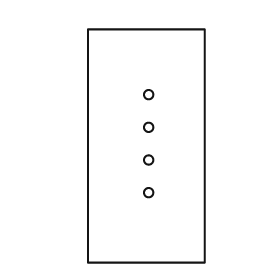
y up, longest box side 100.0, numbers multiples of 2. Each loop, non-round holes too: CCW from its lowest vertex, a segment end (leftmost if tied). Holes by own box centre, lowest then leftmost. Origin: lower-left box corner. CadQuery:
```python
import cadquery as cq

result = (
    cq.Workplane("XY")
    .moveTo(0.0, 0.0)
    .lineTo(50.0, 0.0)
    .lineTo(50.0, 100.0)
    .lineTo(0.0, 100.0)
    .close()
    .moveTo(26.0, 30.0)
    .circle(2.0)
    .moveTo(26.0, 44.0)
    .circle(2.0)
    .moveTo(26.0, 58.0)
    .circle(2.0)
    .moveTo(26.0, 72.0)
    .circle(2.0)
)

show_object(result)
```